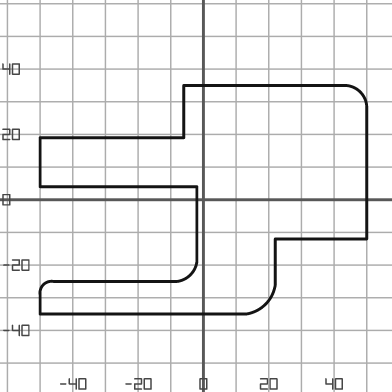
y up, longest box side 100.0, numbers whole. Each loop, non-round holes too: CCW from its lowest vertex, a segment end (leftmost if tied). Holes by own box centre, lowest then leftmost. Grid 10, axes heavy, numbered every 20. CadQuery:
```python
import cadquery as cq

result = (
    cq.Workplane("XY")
    .moveTo(-50.0, -35.0)
    .lineTo(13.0, -35.0)
    .threePointArc((19.0, -32.0), (22.0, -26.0))
    .lineTo(22.0, -12.0)
    .lineTo(50.0, -12.0)
    .lineTo(50.0, 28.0)
    .threePointArc((48.0, 33.0), (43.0, 35.0))
    .lineTo(-6.0, 35.0)
    .lineTo(-6.0, 19.0)
    .lineTo(-50.0, 19.0)
    .lineTo(-50.0, 4.0)
    .lineTo(-2.0, 4.0)
    .lineTo(-2.0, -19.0)
    .threePointArc((-4.0, -23.0), (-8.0, -25.0))
    .lineTo(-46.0, -25.0)
    .threePointArc((-49.0, -26.0), (-50.0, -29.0))
    .close()
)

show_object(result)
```